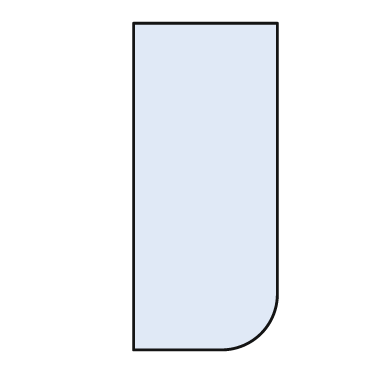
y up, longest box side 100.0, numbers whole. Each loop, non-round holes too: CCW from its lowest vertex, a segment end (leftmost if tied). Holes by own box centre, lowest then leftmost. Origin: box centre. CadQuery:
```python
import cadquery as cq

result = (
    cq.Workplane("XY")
    .moveTo(-22.0, -50.0)
    .lineTo(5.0, -50.0)
    .threePointArc((17.0, -45.0), (22.0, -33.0))
    .lineTo(22.0, 50.0)
    .lineTo(-22.0, 50.0)
    .close()
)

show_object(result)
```